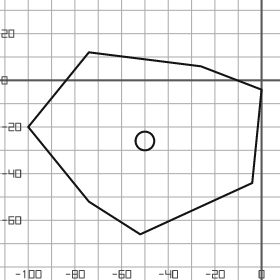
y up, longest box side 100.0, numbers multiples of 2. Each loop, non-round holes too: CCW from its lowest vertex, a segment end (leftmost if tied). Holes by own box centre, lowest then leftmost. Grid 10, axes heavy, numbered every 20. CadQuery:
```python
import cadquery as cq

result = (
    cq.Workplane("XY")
    .moveTo(-52.0, -66.0)
    .lineTo(-4.0, -44.0)
    .lineTo(0.0, -4.0)
    .lineTo(-26.0, 6.0)
    .lineTo(-74.0, 12.0)
    .lineTo(-100.0, -20.0)
    .lineTo(-74.0, -52.0)
    .close()
    .moveTo(-50.0, -26.0)
    .circle(4.0)
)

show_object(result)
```